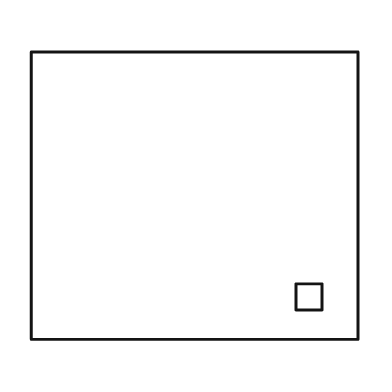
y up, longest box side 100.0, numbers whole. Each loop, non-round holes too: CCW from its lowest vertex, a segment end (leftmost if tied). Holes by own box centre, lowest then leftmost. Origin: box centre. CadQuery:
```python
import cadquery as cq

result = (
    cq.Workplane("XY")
    .moveTo(-50.0, -44.0)
    .lineTo(50.0, -44.0)
    .lineTo(50.0, 44.0)
    .lineTo(-50.0, 44.0)
    .close()
    .moveTo(31.0, -35.0)
    .lineTo(39.0, -35.0)
    .lineTo(39.0, -27.0)
    .lineTo(31.0, -27.0)
    .close()
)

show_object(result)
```